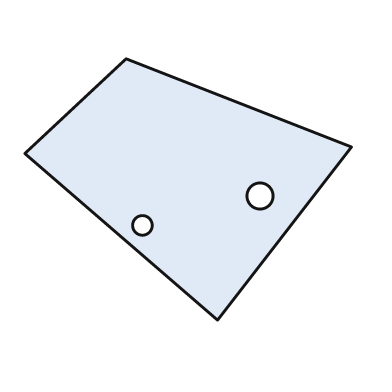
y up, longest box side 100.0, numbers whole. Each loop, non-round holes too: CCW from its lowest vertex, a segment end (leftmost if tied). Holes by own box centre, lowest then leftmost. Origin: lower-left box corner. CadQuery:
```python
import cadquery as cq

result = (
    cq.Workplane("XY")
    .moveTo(59.0, 0.0)
    .lineTo(100.0, 53.0)
    .lineTo(31.0, 80.0)
    .lineTo(0.0, 51.0)
    .close()
    .moveTo(36.0, 29.0)
    .circle(3.0)
    .moveTo(72.0, 38.0)
    .circle(4.0)
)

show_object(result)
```